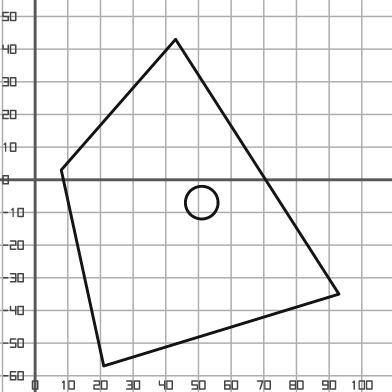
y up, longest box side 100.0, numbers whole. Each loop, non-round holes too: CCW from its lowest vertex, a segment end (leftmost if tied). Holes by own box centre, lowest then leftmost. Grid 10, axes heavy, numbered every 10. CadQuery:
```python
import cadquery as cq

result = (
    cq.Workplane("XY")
    .moveTo(21.0, -57.0)
    .lineTo(93.0, -35.0)
    .lineTo(43.0, 43.0)
    .lineTo(8.0, 3.0)
    .close()
    .moveTo(51.0, -7.0)
    .circle(5.0)
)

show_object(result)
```